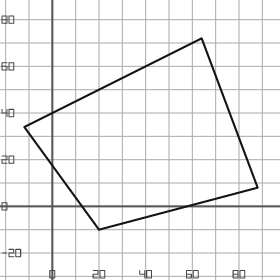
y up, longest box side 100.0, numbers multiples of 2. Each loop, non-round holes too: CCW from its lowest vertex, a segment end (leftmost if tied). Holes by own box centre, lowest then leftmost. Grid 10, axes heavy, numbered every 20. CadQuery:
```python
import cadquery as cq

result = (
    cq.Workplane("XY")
    .moveTo(20.0, -10.0)
    .lineTo(88.0, 8.0)
    .lineTo(64.0, 72.0)
    .lineTo(-12.0, 34.0)
    .close()
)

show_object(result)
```